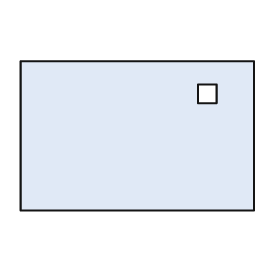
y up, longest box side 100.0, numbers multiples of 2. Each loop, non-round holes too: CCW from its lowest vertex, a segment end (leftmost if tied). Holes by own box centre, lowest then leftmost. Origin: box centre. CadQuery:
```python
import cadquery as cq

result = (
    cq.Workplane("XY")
    .moveTo(-50.0, -32.0)
    .lineTo(50.0, -32.0)
    .lineTo(50.0, 32.0)
    .lineTo(-50.0, 32.0)
    .close()
    .moveTo(26.0, 14.0)
    .lineTo(34.0, 14.0)
    .lineTo(34.0, 22.0)
    .lineTo(26.0, 22.0)
    .close()
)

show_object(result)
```